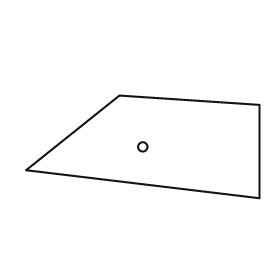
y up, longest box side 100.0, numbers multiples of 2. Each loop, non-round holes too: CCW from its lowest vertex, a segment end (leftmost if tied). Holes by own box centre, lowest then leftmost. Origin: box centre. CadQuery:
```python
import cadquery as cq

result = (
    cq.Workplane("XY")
    .moveTo(50.0, -22.0)
    .lineTo(50.0, 18.0)
    .lineTo(-10.0, 22.0)
    .lineTo(-50.0, -10.0)
    .close()
    .moveTo(0.0, 0.0)
    .circle(2.0)
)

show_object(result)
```